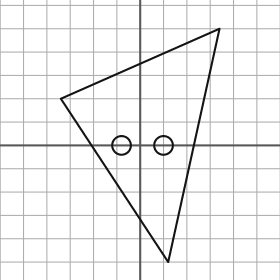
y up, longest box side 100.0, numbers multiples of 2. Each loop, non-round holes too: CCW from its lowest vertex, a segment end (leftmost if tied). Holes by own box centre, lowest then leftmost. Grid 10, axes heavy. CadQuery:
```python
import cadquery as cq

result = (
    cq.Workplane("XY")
    .moveTo(12.0, -50.0)
    .lineTo(34.0, 50.0)
    .lineTo(-34.0, 20.0)
    .close()
    .moveTo(-8.0, 0.0)
    .circle(4.0)
    .moveTo(10.0, 0.0)
    .circle(4.0)
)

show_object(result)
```